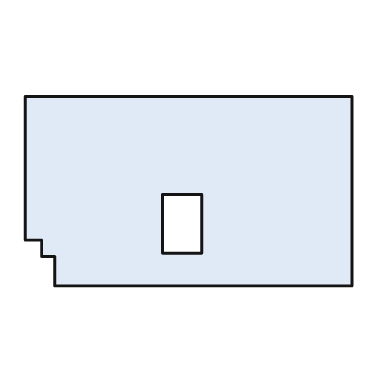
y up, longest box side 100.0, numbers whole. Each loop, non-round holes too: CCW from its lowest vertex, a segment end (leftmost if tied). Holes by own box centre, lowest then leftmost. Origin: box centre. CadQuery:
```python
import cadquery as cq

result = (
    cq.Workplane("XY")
    .moveTo(-41.0, -29.0)
    .lineTo(50.0, -29.0)
    .lineTo(50.0, 29.0)
    .lineTo(-50.0, 29.0)
    .lineTo(-50.0, -15.0)
    .lineTo(-45.0, -15.0)
    .lineTo(-45.0, -20.0)
    .lineTo(-41.0, -20.0)
    .close()
    .moveTo(-8.0, -19.0)
    .lineTo(4.0, -19.0)
    .lineTo(4.0, -1.0)
    .lineTo(-8.0, -1.0)
    .close()
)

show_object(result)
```